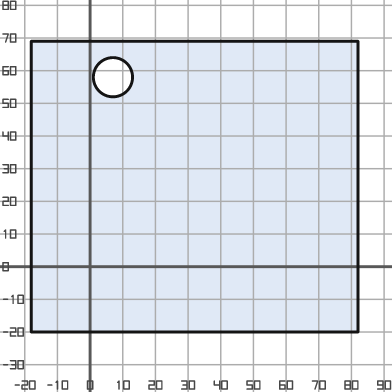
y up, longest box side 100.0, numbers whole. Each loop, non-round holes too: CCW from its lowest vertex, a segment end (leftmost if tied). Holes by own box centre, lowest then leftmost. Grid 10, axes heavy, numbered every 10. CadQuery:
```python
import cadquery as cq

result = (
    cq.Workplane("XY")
    .moveTo(-18.0, -20.0)
    .lineTo(82.0, -20.0)
    .lineTo(82.0, 69.0)
    .lineTo(-18.0, 69.0)
    .close()
    .moveTo(7.0, 58.0)
    .circle(6.0)
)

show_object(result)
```